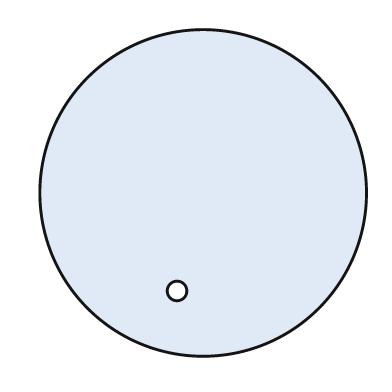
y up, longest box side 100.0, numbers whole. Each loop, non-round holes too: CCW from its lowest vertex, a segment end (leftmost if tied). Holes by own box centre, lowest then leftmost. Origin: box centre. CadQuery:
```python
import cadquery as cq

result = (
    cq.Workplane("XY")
    .moveTo(0.0, 0.0)
    .circle(50.0)
    .moveTo(-8.0, -30.0)
    .circle(3.0)
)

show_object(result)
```